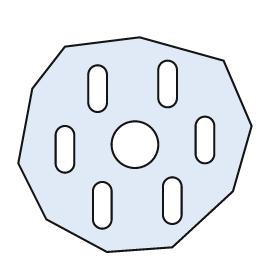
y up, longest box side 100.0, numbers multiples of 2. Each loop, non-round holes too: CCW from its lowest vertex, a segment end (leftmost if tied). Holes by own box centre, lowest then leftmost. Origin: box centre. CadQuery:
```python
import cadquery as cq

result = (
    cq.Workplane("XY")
    .moveTo(-12.0, -46.0)
    .lineTo(16.0, -44.0)
    .lineTo(42.0, -20.0)
    .lineTo(50.0, 8.0)
    .lineTo(38.0, 36.0)
    .lineTo(2.0, 46.0)
    .lineTo(-30.0, 42.0)
    .lineTo(-44.0, 24.0)
    .lineTo(-50.0, -8.0)
    .lineTo(-38.0, -32.0)
    .close()
    .moveTo(-18.0, -32.0)
    .threePointArc((-14.0, -36.0), (-10.0, -32.0))
    .lineTo(-10.0, -20.0)
    .threePointArc((-14.0, -16.0), (-18.0, -20.0))
    .close()
    .moveTo(12.0, -30.0)
    .threePointArc((16.0, -34.0), (20.0, -30.0))
    .lineTo(20.0, -18.0)
    .threePointArc((16.0, -14.0), (12.0, -18.0))
    .close()
    .moveTo(-34.0, -8.0)
    .threePointArc((-30.0, -12.0), (-26.0, -8.0))
    .lineTo(-26.0, 4.0)
    .threePointArc((-30.0, 8.0), (-34.0, 4.0))
    .close()
    .moveTo(0.0, 0.0)
    .circle(10.0)
    .moveTo(26.0, -4.0)
    .threePointArc((30.0, -8.0), (34.0, -4.0))
    .lineTo(34.0, 8.0)
    .threePointArc((30.0, 12.0), (26.0, 8.0))
    .close()
    .moveTo(-20.0, 18.0)
    .threePointArc((-16.0, 14.0), (-12.0, 18.0))
    .lineTo(-12.0, 30.0)
    .threePointArc((-16.0, 34.0), (-20.0, 30.0))
    .close()
    .moveTo(10.0, 20.0)
    .threePointArc((14.0, 16.0), (18.0, 20.0))
    .lineTo(18.0, 32.0)
    .threePointArc((14.0, 36.0), (10.0, 32.0))
    .close()
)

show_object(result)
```